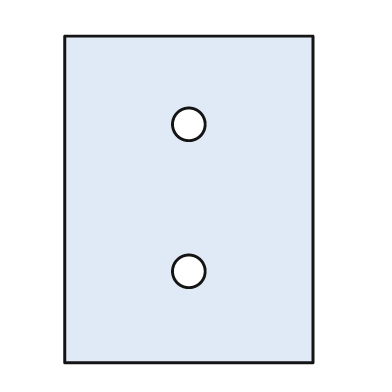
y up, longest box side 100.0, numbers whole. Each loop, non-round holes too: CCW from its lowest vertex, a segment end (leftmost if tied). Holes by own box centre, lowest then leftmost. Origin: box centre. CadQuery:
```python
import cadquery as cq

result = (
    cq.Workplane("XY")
    .moveTo(-38.0, -50.0)
    .lineTo(38.0, -50.0)
    .lineTo(38.0, 50.0)
    .lineTo(-38.0, 50.0)
    .close()
    .moveTo(0.0, -22.0)
    .circle(5.0)
    .moveTo(0.0, 23.0)
    .circle(5.0)
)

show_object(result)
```